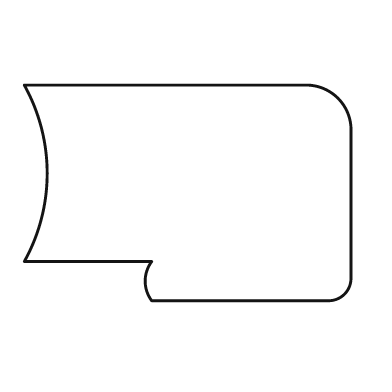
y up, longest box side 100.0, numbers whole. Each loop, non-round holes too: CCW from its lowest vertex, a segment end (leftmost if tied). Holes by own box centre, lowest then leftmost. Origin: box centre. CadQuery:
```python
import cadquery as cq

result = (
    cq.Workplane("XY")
    .moveTo(-11.0, -33.0)
    .lineTo(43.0, -33.0)
    .threePointArc((48.0, -31.0), (50.0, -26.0))
    .lineTo(50.0, 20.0)
    .threePointArc((46.0, 29.0), (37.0, 33.0))
    .lineTo(-50.0, 33.0)
    .threePointArc((-43.0, 6.0), (-50.0, -21.0))
    .lineTo(-11.0, -21.0)
    .threePointArc((-13.0, -27.0), (-11.0, -33.0))
    .close()
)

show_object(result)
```